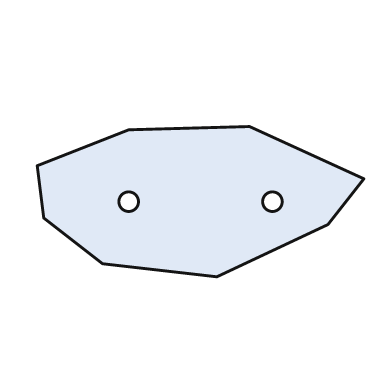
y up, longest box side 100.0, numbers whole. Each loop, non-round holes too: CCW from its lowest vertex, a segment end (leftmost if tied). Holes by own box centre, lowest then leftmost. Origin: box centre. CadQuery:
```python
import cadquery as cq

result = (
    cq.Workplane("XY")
    .moveTo(5.0, -23.0)
    .lineTo(39.0, -7.0)
    .lineTo(50.0, 7.0)
    .lineTo(15.0, 23.0)
    .lineTo(-22.0, 22.0)
    .lineTo(-50.0, 11.0)
    .lineTo(-48.0, -5.0)
    .lineTo(-30.0, -19.0)
    .close()
    .moveTo(-22.0, 0.0)
    .circle(3.0)
    .moveTo(22.0, 0.0)
    .circle(3.0)
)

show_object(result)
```